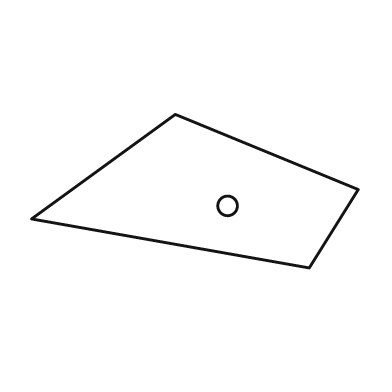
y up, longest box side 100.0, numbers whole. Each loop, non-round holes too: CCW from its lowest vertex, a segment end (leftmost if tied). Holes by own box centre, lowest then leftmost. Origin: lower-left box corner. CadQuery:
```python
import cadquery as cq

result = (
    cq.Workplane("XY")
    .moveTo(85.0, 0.0)
    .lineTo(100.0, 24.0)
    .lineTo(44.0, 47.0)
    .lineTo(0.0, 15.0)
    .close()
    .moveTo(60.0, 19.0)
    .circle(3.0)
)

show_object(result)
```